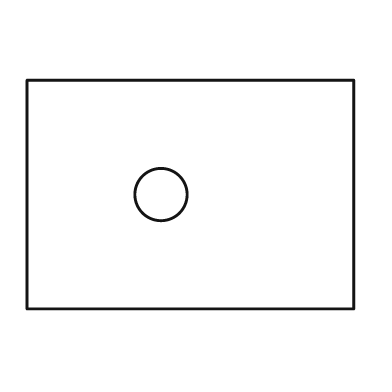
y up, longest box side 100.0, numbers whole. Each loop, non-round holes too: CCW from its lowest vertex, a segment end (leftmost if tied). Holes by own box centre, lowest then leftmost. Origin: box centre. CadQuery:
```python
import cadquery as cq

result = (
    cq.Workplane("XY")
    .moveTo(-50.0, -35.0)
    .lineTo(50.0, -35.0)
    .lineTo(50.0, 35.0)
    .lineTo(-50.0, 35.0)
    .close()
    .moveTo(-9.0, 0.0)
    .circle(8.0)
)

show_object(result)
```